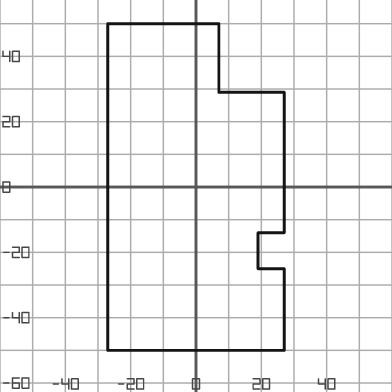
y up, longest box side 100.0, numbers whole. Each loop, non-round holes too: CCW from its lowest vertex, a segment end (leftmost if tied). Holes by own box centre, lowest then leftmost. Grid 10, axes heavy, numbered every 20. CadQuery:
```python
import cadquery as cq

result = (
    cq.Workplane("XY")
    .moveTo(-27.0, -50.0)
    .lineTo(27.0, -50.0)
    .lineTo(27.0, -25.0)
    .lineTo(19.0, -25.0)
    .lineTo(19.0, -14.0)
    .lineTo(27.0, -14.0)
    .lineTo(27.0, 29.0)
    .lineTo(7.0, 29.0)
    .lineTo(7.0, 50.0)
    .lineTo(-27.0, 50.0)
    .close()
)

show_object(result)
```